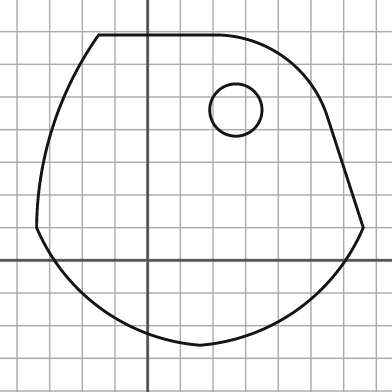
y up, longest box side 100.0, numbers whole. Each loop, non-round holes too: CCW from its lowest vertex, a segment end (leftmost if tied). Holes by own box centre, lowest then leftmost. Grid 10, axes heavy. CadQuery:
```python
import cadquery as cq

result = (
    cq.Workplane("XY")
    .moveTo(16.0, -26.0)
    .threePointArc((46.0, -15.0), (66.0, 10.0))
    .lineTo(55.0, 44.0)
    .threePointArc((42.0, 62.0), (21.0, 69.0))
    .lineTo(-15.0, 69.0)
    .threePointArc((-29.0, 41.0), (-34.0, 10.0))
    .threePointArc((-14.0, -15.0), (16.0, -26.0))
    .close()
    .moveTo(27.0, 46.0)
    .circle(8.0)
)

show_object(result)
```